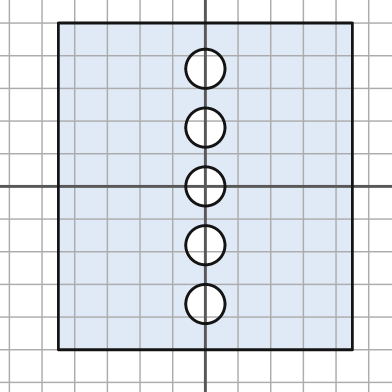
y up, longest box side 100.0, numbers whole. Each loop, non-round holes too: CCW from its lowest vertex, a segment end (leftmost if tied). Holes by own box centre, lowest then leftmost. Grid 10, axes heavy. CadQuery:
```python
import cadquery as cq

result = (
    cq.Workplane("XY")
    .moveTo(-45.0, -50.0)
    .lineTo(45.0, -50.0)
    .lineTo(45.0, 50.0)
    .lineTo(-45.0, 50.0)
    .close()
    .moveTo(0.0, -36.0)
    .circle(6.0)
    .moveTo(0.0, -18.0)
    .circle(6.0)
    .moveTo(0.0, 0.0)
    .circle(6.0)
    .moveTo(0.0, 18.0)
    .circle(6.0)
    .moveTo(0.0, 36.0)
    .circle(6.0)
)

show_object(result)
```